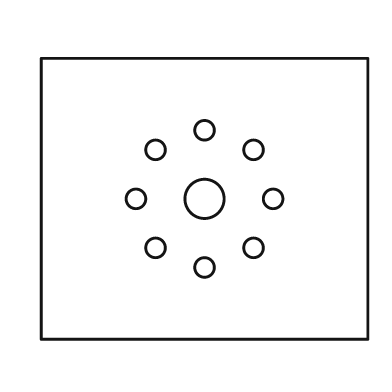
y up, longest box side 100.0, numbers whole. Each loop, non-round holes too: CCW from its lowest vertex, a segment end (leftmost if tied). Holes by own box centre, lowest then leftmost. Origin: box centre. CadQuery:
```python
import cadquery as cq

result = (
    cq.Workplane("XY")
    .moveTo(-50.0, -43.0)
    .lineTo(50.0, -43.0)
    .lineTo(50.0, 43.0)
    .lineTo(-50.0, 43.0)
    .close()
    .moveTo(0.0, -21.0)
    .circle(3.0)
    .moveTo(-15.0, -15.0)
    .circle(3.0)
    .moveTo(15.0, -15.0)
    .circle(3.0)
    .moveTo(-21.0, 0.0)
    .circle(3.0)
    .moveTo(0.0, 0.0)
    .circle(6.0)
    .moveTo(21.0, 0.0)
    .circle(3.0)
    .moveTo(-15.0, 15.0)
    .circle(3.0)
    .moveTo(15.0, 15.0)
    .circle(3.0)
    .moveTo(0.0, 21.0)
    .circle(3.0)
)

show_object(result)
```